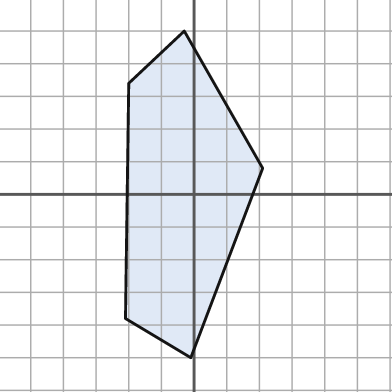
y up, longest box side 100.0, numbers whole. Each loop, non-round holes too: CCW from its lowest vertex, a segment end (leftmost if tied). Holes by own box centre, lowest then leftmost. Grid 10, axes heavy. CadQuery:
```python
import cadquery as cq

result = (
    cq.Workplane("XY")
    .moveTo(-1.0, -50.0)
    .lineTo(21.0, 8.0)
    .lineTo(-3.0, 50.0)
    .lineTo(-20.0, 34.0)
    .lineTo(-21.0, -38.0)
    .close()
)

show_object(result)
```